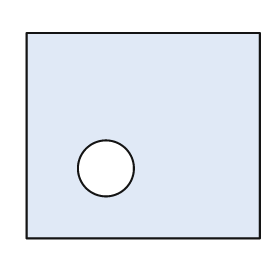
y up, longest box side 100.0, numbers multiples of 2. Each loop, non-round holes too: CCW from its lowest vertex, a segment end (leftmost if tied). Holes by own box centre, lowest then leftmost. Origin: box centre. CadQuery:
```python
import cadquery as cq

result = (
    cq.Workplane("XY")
    .moveTo(-50.0, -44.0)
    .lineTo(50.0, -44.0)
    .lineTo(50.0, 44.0)
    .lineTo(-50.0, 44.0)
    .close()
    .moveTo(-16.0, -14.0)
    .circle(12.0)
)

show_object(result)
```